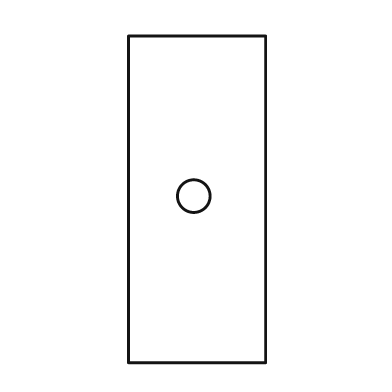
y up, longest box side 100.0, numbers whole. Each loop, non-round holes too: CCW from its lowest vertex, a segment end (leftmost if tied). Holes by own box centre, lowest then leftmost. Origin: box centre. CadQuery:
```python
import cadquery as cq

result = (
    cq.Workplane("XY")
    .moveTo(-21.0, -50.0)
    .lineTo(21.0, -50.0)
    .lineTo(21.0, 50.0)
    .lineTo(-21.0, 50.0)
    .close()
    .moveTo(-1.0, 1.0)
    .circle(5.0)
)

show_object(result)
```